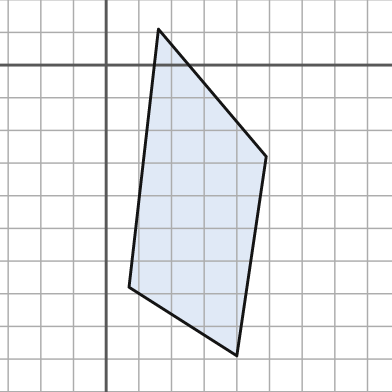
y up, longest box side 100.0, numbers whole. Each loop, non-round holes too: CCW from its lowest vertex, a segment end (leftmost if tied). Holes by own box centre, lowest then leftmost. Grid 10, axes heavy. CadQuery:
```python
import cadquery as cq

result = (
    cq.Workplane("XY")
    .moveTo(40.0, -89.0)
    .lineTo(49.0, -28.0)
    .lineTo(16.0, 11.0)
    .lineTo(7.0, -68.0)
    .close()
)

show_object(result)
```